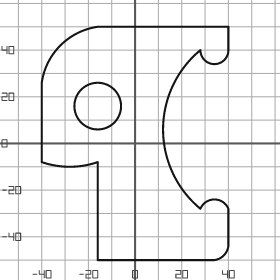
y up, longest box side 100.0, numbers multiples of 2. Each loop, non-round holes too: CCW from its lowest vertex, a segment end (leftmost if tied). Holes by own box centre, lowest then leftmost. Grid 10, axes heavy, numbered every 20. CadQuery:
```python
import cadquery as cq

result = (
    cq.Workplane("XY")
    .moveTo(-16.0, -50.0)
    .lineTo(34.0, -50.0)
    .threePointArc((38.0, -48.0), (40.0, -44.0))
    .lineTo(40.0, -28.0)
    .threePointArc((34.0, -24.0), (28.0, -28.0))
    .threePointArc((12.0, 6.0), (28.0, 40.0))
    .threePointArc((34.0, 34.0), (40.0, 40.0))
    .lineTo(40.0, 50.0)
    .lineTo(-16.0, 50.0)
    .threePointArc((-32.0, 42.0), (-40.0, 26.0))
    .lineTo(-40.0, -8.0)
    .threePointArc((-28.0, -10.0), (-16.0, -8.0))
    .close()
    .moveTo(-16.0, 16.0)
    .circle(10.0)
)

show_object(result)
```